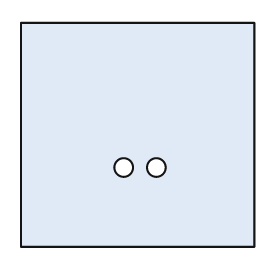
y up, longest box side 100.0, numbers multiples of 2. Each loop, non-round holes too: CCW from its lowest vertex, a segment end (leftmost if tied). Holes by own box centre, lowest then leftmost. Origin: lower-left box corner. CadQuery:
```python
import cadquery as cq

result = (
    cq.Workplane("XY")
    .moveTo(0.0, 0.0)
    .lineTo(100.0, 0.0)
    .lineTo(100.0, 96.0)
    .lineTo(0.0, 96.0)
    .close()
    .moveTo(44.0, 34.0)
    .circle(4.0)
    .moveTo(58.0, 34.0)
    .circle(4.0)
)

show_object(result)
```